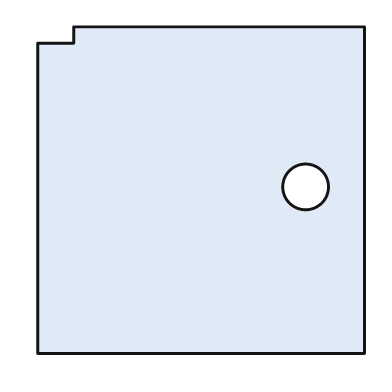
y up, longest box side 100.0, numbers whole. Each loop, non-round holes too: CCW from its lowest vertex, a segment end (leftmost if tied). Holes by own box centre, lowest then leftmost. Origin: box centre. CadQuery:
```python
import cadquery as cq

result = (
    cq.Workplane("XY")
    .moveTo(-50.0, -50.0)
    .lineTo(50.0, -50.0)
    .lineTo(50.0, 50.0)
    .lineTo(-39.0, 50.0)
    .lineTo(-39.0, 45.0)
    .lineTo(-50.0, 45.0)
    .close()
    .moveTo(32.0, 1.0)
    .circle(7.0)
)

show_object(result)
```